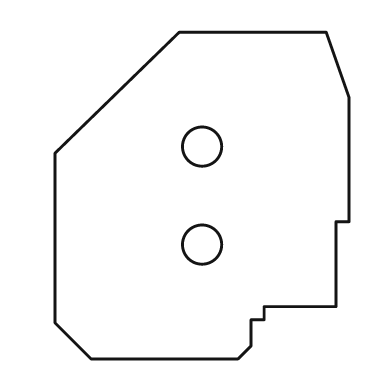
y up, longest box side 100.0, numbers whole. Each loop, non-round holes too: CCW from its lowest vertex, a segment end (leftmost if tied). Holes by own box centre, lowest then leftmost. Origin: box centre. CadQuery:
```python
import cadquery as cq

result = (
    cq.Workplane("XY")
    .moveTo(-34.0, -50.0)
    .lineTo(11.0, -50.0)
    .lineTo(15.0, -46.0)
    .lineTo(15.0, -38.0)
    .lineTo(19.0, -38.0)
    .lineTo(19.0, -34.0)
    .lineTo(41.0, -34.0)
    .lineTo(41.0, -8.0)
    .lineTo(45.0, -8.0)
    .lineTo(45.0, 30.0)
    .lineTo(38.0, 50.0)
    .lineTo(-7.0, 50.0)
    .lineTo(-45.0, 13.0)
    .lineTo(-45.0, -39.0)
    .close()
    .moveTo(0.0, -15.0)
    .circle(6.0)
    .moveTo(0.0, 15.0)
    .circle(6.0)
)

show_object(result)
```